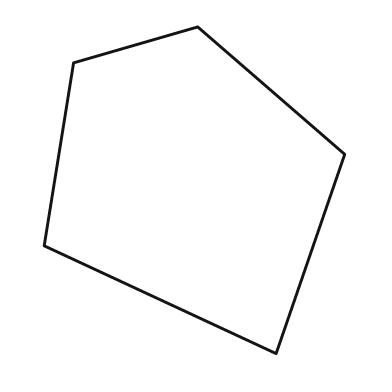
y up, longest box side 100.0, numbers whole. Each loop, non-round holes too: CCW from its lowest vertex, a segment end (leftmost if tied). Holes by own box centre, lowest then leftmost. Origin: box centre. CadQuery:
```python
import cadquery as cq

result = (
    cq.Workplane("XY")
    .moveTo(25.0, -50.0)
    .lineTo(46.0, 11.0)
    .lineTo(1.0, 50.0)
    .lineTo(-37.0, 39.0)
    .lineTo(-46.0, -17.0)
    .close()
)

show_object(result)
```